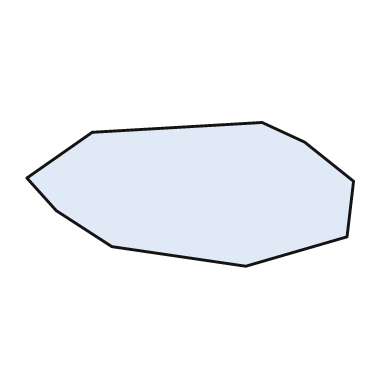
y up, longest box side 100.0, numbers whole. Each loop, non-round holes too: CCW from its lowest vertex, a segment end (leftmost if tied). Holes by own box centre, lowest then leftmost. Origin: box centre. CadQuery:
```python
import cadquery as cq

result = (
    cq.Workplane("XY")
    .moveTo(17.0, -22.0)
    .lineTo(48.0, -13.0)
    .lineTo(50.0, 4.0)
    .lineTo(35.0, 16.0)
    .lineTo(22.0, 22.0)
    .lineTo(-30.0, 19.0)
    .lineTo(-50.0, 5.0)
    .lineTo(-41.0, -5.0)
    .lineTo(-24.0, -16.0)
    .close()
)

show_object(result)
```